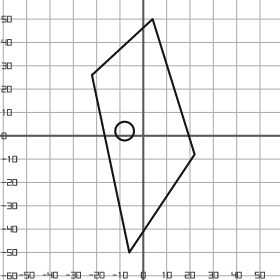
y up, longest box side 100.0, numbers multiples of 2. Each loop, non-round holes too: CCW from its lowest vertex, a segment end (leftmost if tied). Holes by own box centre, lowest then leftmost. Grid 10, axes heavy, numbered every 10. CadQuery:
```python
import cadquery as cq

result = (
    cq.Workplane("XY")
    .moveTo(-6.0, -50.0)
    .lineTo(22.0, -8.0)
    .lineTo(4.0, 50.0)
    .lineTo(-22.0, 26.0)
    .close()
    .moveTo(-8.0, 2.0)
    .circle(4.0)
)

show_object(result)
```